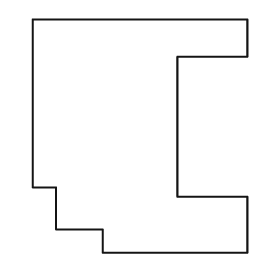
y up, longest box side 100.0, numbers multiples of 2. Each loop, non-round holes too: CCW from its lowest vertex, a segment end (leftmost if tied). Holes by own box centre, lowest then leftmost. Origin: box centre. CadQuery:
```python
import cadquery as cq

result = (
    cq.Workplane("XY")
    .moveTo(-16.0, -50.0)
    .lineTo(46.0, -50.0)
    .lineTo(46.0, -26.0)
    .lineTo(16.0, -26.0)
    .lineTo(16.0, 34.0)
    .lineTo(46.0, 34.0)
    .lineTo(46.0, 50.0)
    .lineTo(-46.0, 50.0)
    .lineTo(-46.0, -22.0)
    .lineTo(-36.0, -22.0)
    .lineTo(-36.0, -40.0)
    .lineTo(-16.0, -40.0)
    .close()
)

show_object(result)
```